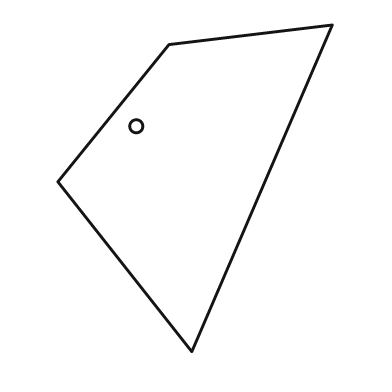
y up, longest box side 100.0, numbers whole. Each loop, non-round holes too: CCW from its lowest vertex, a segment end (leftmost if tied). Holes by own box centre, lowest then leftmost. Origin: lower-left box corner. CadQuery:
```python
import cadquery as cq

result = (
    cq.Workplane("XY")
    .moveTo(41.0, 0.0)
    .lineTo(84.0, 100.0)
    .lineTo(34.0, 94.0)
    .lineTo(0.0, 52.0)
    .close()
    .moveTo(24.0, 69.0)
    .circle(2.0)
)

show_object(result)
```